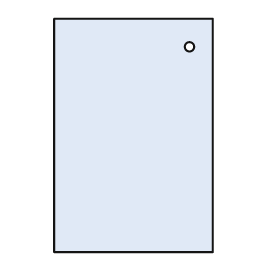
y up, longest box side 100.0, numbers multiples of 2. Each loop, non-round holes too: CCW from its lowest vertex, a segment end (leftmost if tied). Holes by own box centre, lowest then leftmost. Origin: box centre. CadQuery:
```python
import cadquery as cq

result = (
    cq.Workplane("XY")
    .moveTo(-34.0, -50.0)
    .lineTo(34.0, -50.0)
    .lineTo(34.0, 50.0)
    .lineTo(-34.0, 50.0)
    .close()
    .moveTo(24.0, 38.0)
    .circle(2.0)
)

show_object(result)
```